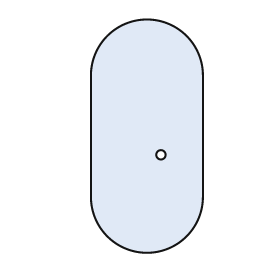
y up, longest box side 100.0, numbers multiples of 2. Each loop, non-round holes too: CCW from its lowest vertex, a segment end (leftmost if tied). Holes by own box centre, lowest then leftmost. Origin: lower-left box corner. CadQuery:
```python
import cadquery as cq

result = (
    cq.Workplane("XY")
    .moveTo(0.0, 24.0)
    .threePointArc((24.0, 0.0), (48.0, 24.0))
    .lineTo(48.0, 76.0)
    .threePointArc((24.0, 100.0), (0.0, 76.0))
    .close()
    .moveTo(30.0, 42.0)
    .circle(2.0)
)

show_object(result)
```